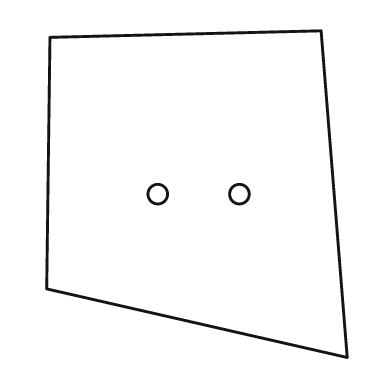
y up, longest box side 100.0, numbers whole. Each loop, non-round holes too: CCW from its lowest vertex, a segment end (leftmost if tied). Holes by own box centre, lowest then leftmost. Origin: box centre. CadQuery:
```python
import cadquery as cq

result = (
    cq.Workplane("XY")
    .moveTo(46.0, -50.0)
    .lineTo(38.0, 50.0)
    .lineTo(-45.0, 48.0)
    .lineTo(-46.0, -29.0)
    .close()
    .moveTo(-12.0, 0.0)
    .circle(3.0)
    .moveTo(13.0, 0.0)
    .circle(3.0)
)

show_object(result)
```